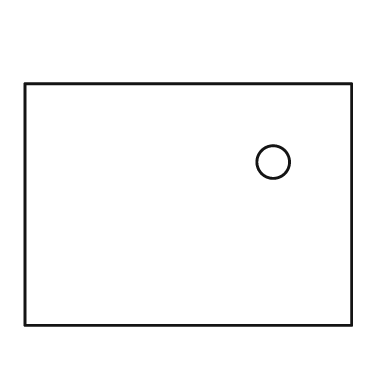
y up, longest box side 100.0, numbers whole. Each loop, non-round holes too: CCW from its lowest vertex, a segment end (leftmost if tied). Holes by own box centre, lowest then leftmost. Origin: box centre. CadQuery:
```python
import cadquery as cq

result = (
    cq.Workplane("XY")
    .moveTo(-50.0, -37.0)
    .lineTo(50.0, -37.0)
    .lineTo(50.0, 37.0)
    .lineTo(-50.0, 37.0)
    .close()
    .moveTo(26.0, 13.0)
    .circle(5.0)
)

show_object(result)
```